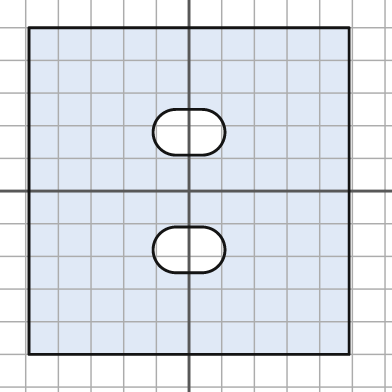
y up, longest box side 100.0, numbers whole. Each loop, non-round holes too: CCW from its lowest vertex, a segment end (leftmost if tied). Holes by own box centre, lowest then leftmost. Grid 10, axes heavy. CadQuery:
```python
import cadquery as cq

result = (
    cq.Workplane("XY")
    .moveTo(-49.0, -50.0)
    .lineTo(49.0, -50.0)
    .lineTo(49.0, 50.0)
    .lineTo(-49.0, 50.0)
    .close()
    .moveTo(-4.0, -25.0)
    .lineTo(4.0, -25.0)
    .threePointArc((11.0, -18.0), (4.0, -11.0))
    .lineTo(-4.0, -11.0)
    .threePointArc((-11.0, -18.0), (-4.0, -25.0))
    .close()
    .moveTo(-4.0, 11.0)
    .lineTo(4.0, 11.0)
    .threePointArc((11.0, 18.0), (4.0, 25.0))
    .lineTo(-4.0, 25.0)
    .threePointArc((-11.0, 18.0), (-4.0, 11.0))
    .close()
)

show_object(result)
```